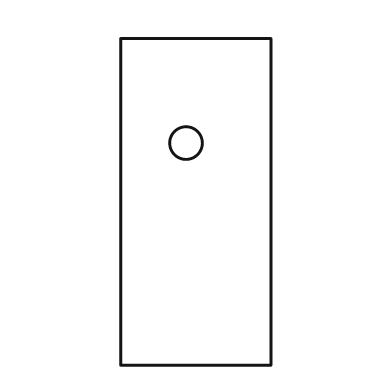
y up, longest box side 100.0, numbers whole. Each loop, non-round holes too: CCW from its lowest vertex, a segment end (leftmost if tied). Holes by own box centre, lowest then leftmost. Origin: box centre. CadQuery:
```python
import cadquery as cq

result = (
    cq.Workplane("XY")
    .moveTo(-23.0, -50.0)
    .lineTo(23.0, -50.0)
    .lineTo(23.0, 50.0)
    .lineTo(-23.0, 50.0)
    .close()
    .moveTo(-3.0, 18.0)
    .circle(5.0)
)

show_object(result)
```